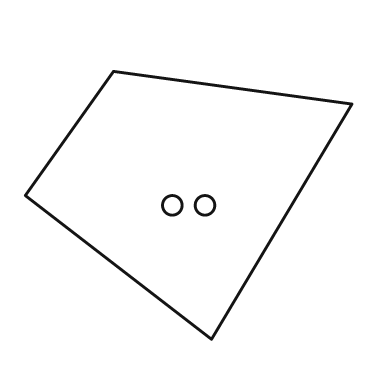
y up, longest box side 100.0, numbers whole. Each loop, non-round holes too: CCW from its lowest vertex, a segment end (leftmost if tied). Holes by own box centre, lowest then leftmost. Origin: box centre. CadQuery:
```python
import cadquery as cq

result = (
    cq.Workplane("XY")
    .moveTo(7.0, -41.0)
    .lineTo(50.0, 31.0)
    .lineTo(-23.0, 41.0)
    .lineTo(-50.0, 3.0)
    .close()
    .moveTo(-5.0, 0.0)
    .circle(3.0)
    .moveTo(5.0, 0.0)
    .circle(3.0)
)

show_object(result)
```